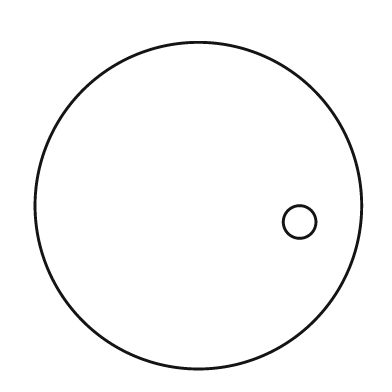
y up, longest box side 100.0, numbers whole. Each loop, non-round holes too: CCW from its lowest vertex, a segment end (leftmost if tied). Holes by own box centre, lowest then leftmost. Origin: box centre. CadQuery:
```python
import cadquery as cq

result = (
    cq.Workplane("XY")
    .moveTo(0.0, 0.0)
    .circle(50.0)
    .moveTo(31.0, -5.0)
    .circle(5.0)
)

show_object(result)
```